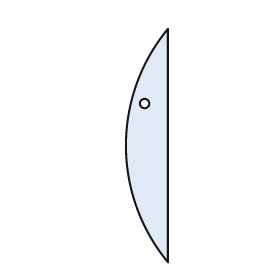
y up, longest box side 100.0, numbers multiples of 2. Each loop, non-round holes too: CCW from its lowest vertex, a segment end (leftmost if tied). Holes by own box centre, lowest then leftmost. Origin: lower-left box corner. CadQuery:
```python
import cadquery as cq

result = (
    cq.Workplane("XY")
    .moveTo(18.0, 0.0)
    .lineTo(18.0, 100.0)
    .threePointArc((0.0, 50.0), (18.0, 0.0))
    .close()
    .moveTo(8.0, 68.0)
    .circle(2.0)
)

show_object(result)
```